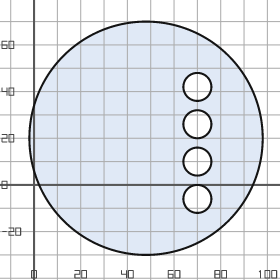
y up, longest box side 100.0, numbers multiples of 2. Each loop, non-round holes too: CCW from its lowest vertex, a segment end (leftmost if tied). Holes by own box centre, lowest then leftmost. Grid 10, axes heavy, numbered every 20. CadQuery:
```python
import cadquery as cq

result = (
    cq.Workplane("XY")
    .moveTo(48.0, 20.0)
    .circle(50.0)
    .moveTo(70.0, -6.0)
    .circle(6.0)
    .moveTo(70.0, 10.0)
    .circle(6.0)
    .moveTo(70.0, 26.0)
    .circle(6.0)
    .moveTo(70.0, 42.0)
    .circle(6.0)
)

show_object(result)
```